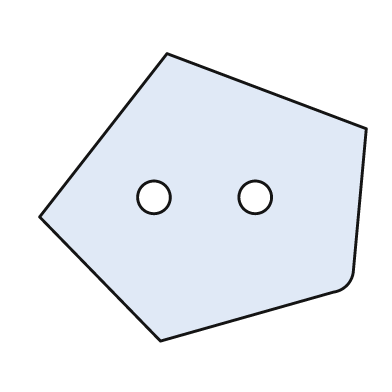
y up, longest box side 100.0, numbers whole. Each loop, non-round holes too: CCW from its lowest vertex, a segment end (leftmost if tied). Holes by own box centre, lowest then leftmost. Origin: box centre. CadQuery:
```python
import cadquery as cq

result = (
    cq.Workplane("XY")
    .moveTo(-13.0, -44.0)
    .lineTo(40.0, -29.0)
    .threePointArc((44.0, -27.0), (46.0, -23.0))
    .lineTo(50.0, 21.0)
    .lineTo(-11.0, 44.0)
    .lineTo(-50.0, -6.0)
    .close()
    .moveTo(-15.0, 0.0)
    .circle(5.0)
    .moveTo(16.0, 0.0)
    .circle(5.0)
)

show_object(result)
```